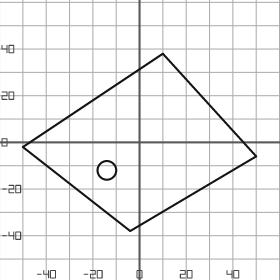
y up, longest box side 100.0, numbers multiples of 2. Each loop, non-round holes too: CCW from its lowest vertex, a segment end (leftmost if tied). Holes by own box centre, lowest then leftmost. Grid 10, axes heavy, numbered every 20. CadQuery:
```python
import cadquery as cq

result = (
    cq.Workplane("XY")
    .moveTo(-4.0, -38.0)
    .lineTo(50.0, -6.0)
    .lineTo(10.0, 38.0)
    .lineTo(-50.0, -2.0)
    .close()
    .moveTo(-14.0, -12.0)
    .circle(4.0)
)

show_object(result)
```